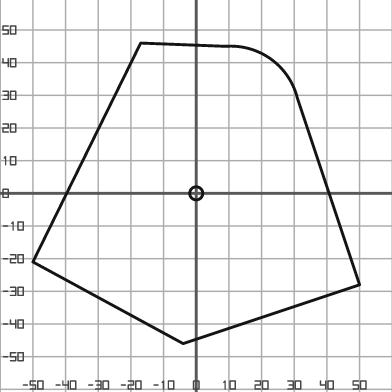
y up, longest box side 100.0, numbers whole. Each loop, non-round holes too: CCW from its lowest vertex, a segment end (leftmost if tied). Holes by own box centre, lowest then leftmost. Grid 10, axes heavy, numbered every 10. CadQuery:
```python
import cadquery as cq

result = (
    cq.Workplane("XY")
    .moveTo(-4.0, -46.0)
    .lineTo(50.0, -28.0)
    .lineTo(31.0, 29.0)
    .threePointArc((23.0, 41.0), (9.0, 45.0))
    .lineTo(-17.0, 46.0)
    .lineTo(-50.0, -21.0)
    .close()
    .moveTo(0.0, 0.0)
    .circle(2.0)
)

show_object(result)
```